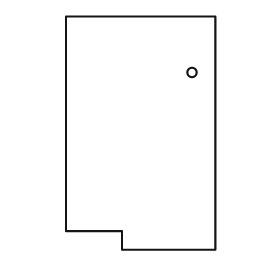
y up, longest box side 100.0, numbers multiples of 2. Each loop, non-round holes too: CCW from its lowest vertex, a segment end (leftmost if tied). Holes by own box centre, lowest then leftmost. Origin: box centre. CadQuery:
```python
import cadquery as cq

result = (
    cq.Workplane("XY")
    .moveTo(-8.0, -50.0)
    .lineTo(32.0, -50.0)
    .lineTo(32.0, 50.0)
    .lineTo(-32.0, 50.0)
    .lineTo(-32.0, -42.0)
    .lineTo(-8.0, -42.0)
    .close()
    .moveTo(22.0, 26.0)
    .circle(2.0)
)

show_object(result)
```